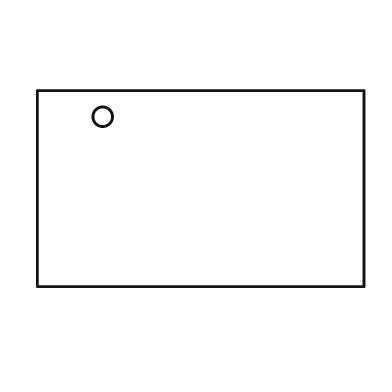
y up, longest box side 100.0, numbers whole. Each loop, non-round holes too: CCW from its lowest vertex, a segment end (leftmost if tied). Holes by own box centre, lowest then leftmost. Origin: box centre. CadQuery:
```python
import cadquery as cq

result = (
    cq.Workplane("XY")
    .moveTo(-50.0, -30.0)
    .lineTo(50.0, -30.0)
    .lineTo(50.0, 30.0)
    .lineTo(-50.0, 30.0)
    .close()
    .moveTo(-30.0, 22.0)
    .circle(3.0)
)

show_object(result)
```